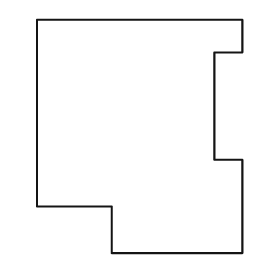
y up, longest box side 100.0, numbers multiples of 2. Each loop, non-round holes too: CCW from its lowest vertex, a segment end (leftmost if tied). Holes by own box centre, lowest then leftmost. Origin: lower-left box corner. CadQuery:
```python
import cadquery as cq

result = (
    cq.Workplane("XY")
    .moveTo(32.0, 0.0)
    .lineTo(88.0, 0.0)
    .lineTo(88.0, 40.0)
    .lineTo(76.0, 40.0)
    .lineTo(76.0, 86.0)
    .lineTo(88.0, 86.0)
    .lineTo(88.0, 100.0)
    .lineTo(0.0, 100.0)
    .lineTo(0.0, 20.0)
    .lineTo(32.0, 20.0)
    .close()
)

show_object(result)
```